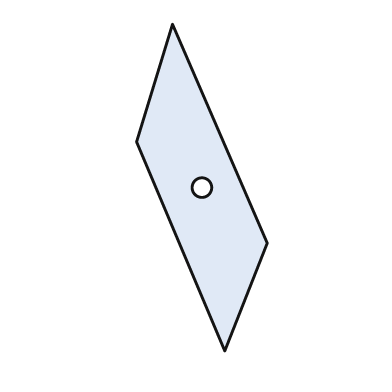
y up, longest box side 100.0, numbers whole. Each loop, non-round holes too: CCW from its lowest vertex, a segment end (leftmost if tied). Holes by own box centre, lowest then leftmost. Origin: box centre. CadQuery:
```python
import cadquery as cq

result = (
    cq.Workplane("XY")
    .moveTo(7.0, -50.0)
    .lineTo(20.0, -17.0)
    .lineTo(-9.0, 50.0)
    .lineTo(-20.0, 14.0)
    .close()
    .moveTo(0.0, 0.0)
    .circle(3.0)
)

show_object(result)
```